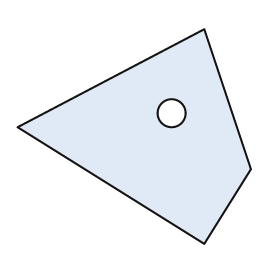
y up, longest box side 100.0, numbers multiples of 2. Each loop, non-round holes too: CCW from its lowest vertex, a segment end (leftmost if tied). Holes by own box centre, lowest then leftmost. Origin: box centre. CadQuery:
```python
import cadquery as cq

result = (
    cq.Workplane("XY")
    .moveTo(30.0, -46.0)
    .lineTo(50.0, -14.0)
    .lineTo(30.0, 46.0)
    .lineTo(-50.0, 4.0)
    .close()
    .moveTo(16.0, 10.0)
    .circle(6.0)
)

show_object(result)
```